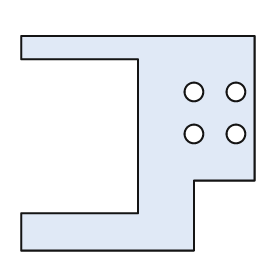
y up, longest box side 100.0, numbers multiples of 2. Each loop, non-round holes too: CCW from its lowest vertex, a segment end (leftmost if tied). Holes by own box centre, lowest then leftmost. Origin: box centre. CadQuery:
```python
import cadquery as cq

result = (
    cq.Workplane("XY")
    .moveTo(-50.0, -46.0)
    .lineTo(24.0, -46.0)
    .lineTo(24.0, -16.0)
    .lineTo(50.0, -16.0)
    .lineTo(50.0, 46.0)
    .lineTo(-50.0, 46.0)
    .lineTo(-50.0, 36.0)
    .lineTo(0.0, 36.0)
    .lineTo(0.0, -30.0)
    .lineTo(-50.0, -30.0)
    .close()
    .moveTo(24.0, 4.0)
    .circle(4.0)
    .moveTo(42.0, 4.0)
    .circle(4.0)
    .moveTo(24.0, 22.0)
    .circle(4.0)
    .moveTo(42.0, 22.0)
    .circle(4.0)
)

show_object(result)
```